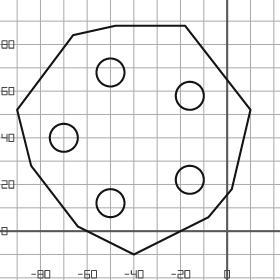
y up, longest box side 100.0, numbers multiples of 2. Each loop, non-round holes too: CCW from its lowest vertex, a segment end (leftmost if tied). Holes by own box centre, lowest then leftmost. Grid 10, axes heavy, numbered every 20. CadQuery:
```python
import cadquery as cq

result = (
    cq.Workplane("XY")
    .moveTo(-40.0, -10.0)
    .lineTo(-8.0, 6.0)
    .lineTo(2.0, 18.0)
    .lineTo(10.0, 52.0)
    .lineTo(-18.0, 88.0)
    .lineTo(-48.0, 88.0)
    .lineTo(-66.0, 84.0)
    .lineTo(-90.0, 52.0)
    .lineTo(-84.0, 28.0)
    .lineTo(-64.0, 2.0)
    .close()
    .moveTo(-50.0, 12.0)
    .circle(6.0)
    .moveTo(-16.0, 22.0)
    .circle(6.0)
    .moveTo(-70.0, 40.0)
    .circle(6.0)
    .moveTo(-16.0, 58.0)
    .circle(6.0)
    .moveTo(-50.0, 68.0)
    .circle(6.0)
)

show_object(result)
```